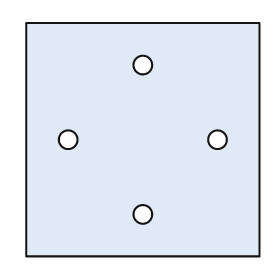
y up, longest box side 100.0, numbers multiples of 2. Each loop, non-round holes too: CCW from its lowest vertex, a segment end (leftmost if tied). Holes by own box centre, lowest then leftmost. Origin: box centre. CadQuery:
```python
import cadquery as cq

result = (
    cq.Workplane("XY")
    .moveTo(-50.0, -50.0)
    .lineTo(50.0, -50.0)
    .lineTo(50.0, 50.0)
    .lineTo(-50.0, 50.0)
    .close()
    .moveTo(0.0, -32.0)
    .circle(4.0)
    .moveTo(-32.0, 0.0)
    .circle(4.0)
    .moveTo(32.0, 0.0)
    .circle(4.0)
    .moveTo(0.0, 32.0)
    .circle(4.0)
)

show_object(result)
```